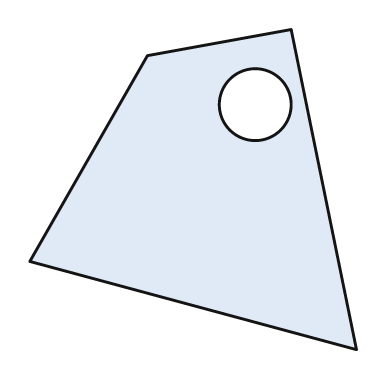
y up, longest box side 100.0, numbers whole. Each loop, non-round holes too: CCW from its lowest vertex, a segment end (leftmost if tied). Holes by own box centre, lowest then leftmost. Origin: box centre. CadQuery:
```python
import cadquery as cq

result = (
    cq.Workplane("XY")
    .moveTo(50.0, -49.0)
    .lineTo(30.0, 49.0)
    .lineTo(-14.0, 41.0)
    .lineTo(-50.0, -22.0)
    .close()
    .moveTo(19.0, 26.0)
    .circle(11.0)
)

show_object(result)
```